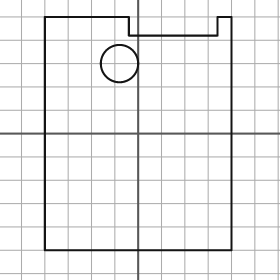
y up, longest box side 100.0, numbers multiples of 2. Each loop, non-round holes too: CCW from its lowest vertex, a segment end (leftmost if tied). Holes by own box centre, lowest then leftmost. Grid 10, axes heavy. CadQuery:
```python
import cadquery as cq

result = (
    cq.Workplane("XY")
    .moveTo(-40.0, -50.0)
    .lineTo(40.0, -50.0)
    .lineTo(40.0, 50.0)
    .lineTo(34.0, 50.0)
    .lineTo(34.0, 42.0)
    .lineTo(-4.0, 42.0)
    .lineTo(-4.0, 50.0)
    .lineTo(-40.0, 50.0)
    .close()
    .moveTo(-8.0, 30.0)
    .circle(8.0)
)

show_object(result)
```